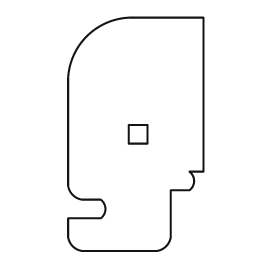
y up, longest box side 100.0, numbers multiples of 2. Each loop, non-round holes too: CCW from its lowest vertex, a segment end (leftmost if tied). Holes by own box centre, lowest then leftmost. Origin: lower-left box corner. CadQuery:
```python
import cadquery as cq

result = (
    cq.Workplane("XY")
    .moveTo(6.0, 0.0)
    .lineTo(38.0, 0.0)
    .threePointArc((42.0, 2.0), (44.0, 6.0))
    .lineTo(44.0, 26.0)
    .lineTo(52.0, 26.0)
    .threePointArc((54.0, 30.0), (52.0, 34.0))
    .lineTo(58.0, 34.0)
    .lineTo(58.0, 100.0)
    .lineTo(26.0, 100.0)
    .threePointArc((8.0, 92.0), (0.0, 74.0))
    .lineTo(0.0, 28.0)
    .threePointArc((2.0, 24.0), (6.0, 22.0))
    .lineTo(14.0, 22.0)
    .threePointArc((16.0, 18.0), (14.0, 14.0))
    .lineTo(0.0, 14.0)
    .lineTo(0.0, 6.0)
    .threePointArc((2.0, 2.0), (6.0, 0.0))
    .close()
    .moveTo(26.0, 46.0)
    .lineTo(34.0, 46.0)
    .lineTo(34.0, 54.0)
    .lineTo(26.0, 54.0)
    .close()
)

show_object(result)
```